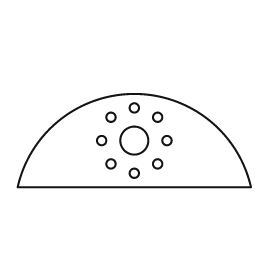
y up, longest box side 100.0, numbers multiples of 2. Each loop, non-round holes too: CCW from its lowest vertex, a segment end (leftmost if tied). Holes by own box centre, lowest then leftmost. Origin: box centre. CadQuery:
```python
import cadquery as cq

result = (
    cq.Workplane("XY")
    .moveTo(-50.0, -20.0)
    .lineTo(50.0, -20.0)
    .threePointArc((0.0, 20.0), (-50.0, -20.0))
    .close()
    .moveTo(0.0, -14.0)
    .circle(2.0)
    .moveTo(-10.0, -10.0)
    .circle(2.0)
    .moveTo(10.0, -10.0)
    .circle(2.0)
    .moveTo(-14.0, 0.0)
    .circle(2.0)
    .moveTo(0.0, 0.0)
    .circle(6.0)
    .moveTo(14.0, 0.0)
    .circle(2.0)
    .moveTo(-10.0, 10.0)
    .circle(2.0)
    .moveTo(10.0, 10.0)
    .circle(2.0)
    .moveTo(0.0, 14.0)
    .circle(2.0)
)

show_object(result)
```